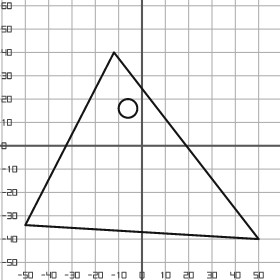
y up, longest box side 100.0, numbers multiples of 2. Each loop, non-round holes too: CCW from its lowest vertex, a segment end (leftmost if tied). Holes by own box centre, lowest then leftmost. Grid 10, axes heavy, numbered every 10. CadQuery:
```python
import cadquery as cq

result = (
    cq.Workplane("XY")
    .moveTo(50.0, -40.0)
    .lineTo(-12.0, 40.0)
    .lineTo(-50.0, -34.0)
    .close()
    .moveTo(-6.0, 16.0)
    .circle(4.0)
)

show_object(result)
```